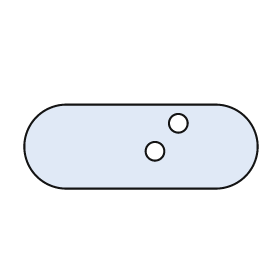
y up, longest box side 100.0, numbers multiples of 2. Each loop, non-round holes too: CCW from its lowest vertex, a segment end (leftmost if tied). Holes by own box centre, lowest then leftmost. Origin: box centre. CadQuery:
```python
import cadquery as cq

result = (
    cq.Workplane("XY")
    .moveTo(-32.0, -18.0)
    .lineTo(32.0, -18.0)
    .threePointArc((50.0, 0.0), (32.0, 18.0))
    .lineTo(-32.0, 18.0)
    .threePointArc((-50.0, 0.0), (-32.0, -18.0))
    .close()
    .moveTo(6.0, -2.0)
    .circle(4.0)
    .moveTo(16.0, 10.0)
    .circle(4.0)
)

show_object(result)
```